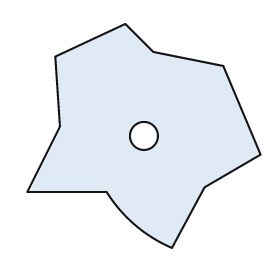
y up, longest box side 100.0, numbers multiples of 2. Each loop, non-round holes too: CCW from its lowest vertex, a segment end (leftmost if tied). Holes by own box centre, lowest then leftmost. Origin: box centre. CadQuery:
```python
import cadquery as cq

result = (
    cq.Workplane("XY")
    .moveTo(12.0, -48.0)
    .lineTo(26.0, -22.0)
    .lineTo(50.0, -8.0)
    .lineTo(34.0, 30.0)
    .lineTo(4.0, 36.0)
    .lineTo(-8.0, 48.0)
    .lineTo(-38.0, 34.0)
    .lineTo(-36.0, 4.0)
    .lineTo(-50.0, -24.0)
    .lineTo(-16.0, -24.0)
    .threePointArc((-4.0, -38.0), (12.0, -48.0))
    .close()
    .moveTo(0.0, 0.0)
    .circle(6.0)
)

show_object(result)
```